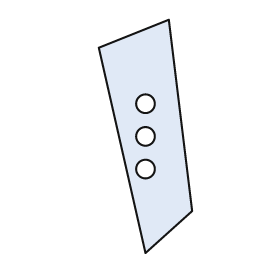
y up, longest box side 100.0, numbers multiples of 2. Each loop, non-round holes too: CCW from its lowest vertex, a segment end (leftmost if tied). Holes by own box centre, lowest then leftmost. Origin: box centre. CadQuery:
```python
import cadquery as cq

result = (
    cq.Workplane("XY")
    .moveTo(0.0, -50.0)
    .lineTo(20.0, -32.0)
    .lineTo(10.0, 50.0)
    .lineTo(-20.0, 38.0)
    .close()
    .moveTo(0.0, -14.0)
    .circle(4.0)
    .moveTo(0.0, 0.0)
    .circle(4.0)
    .moveTo(0.0, 14.0)
    .circle(4.0)
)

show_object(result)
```